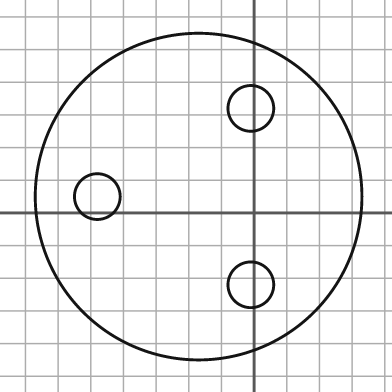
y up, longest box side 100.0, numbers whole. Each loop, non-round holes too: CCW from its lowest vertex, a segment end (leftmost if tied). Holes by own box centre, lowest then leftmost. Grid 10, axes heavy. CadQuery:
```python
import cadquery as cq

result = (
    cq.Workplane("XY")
    .moveTo(-17.0, 5.0)
    .circle(50.0)
    .moveTo(-1.0, -22.0)
    .circle(7.0)
    .moveTo(-48.0, 5.0)
    .circle(7.0)
    .moveTo(-1.0, 32.0)
    .circle(7.0)
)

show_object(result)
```